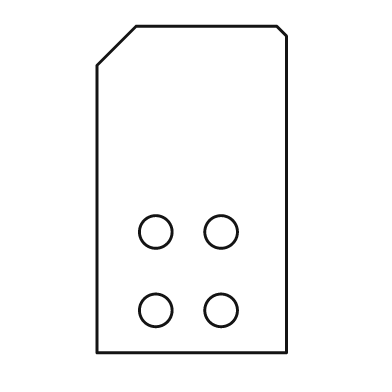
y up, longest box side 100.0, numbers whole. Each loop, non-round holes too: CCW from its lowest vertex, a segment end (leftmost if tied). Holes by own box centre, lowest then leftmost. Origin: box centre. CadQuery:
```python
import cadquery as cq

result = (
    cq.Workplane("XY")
    .moveTo(-29.0, -50.0)
    .lineTo(29.0, -50.0)
    .lineTo(29.0, 47.0)
    .lineTo(26.0, 50.0)
    .lineTo(-17.0, 50.0)
    .lineTo(-29.0, 38.0)
    .close()
    .moveTo(-11.0, -37.0)
    .circle(5.0)
    .moveTo(9.0, -37.0)
    .circle(5.0)
    .moveTo(-11.0, -13.0)
    .circle(5.0)
    .moveTo(9.0, -13.0)
    .circle(5.0)
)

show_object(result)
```